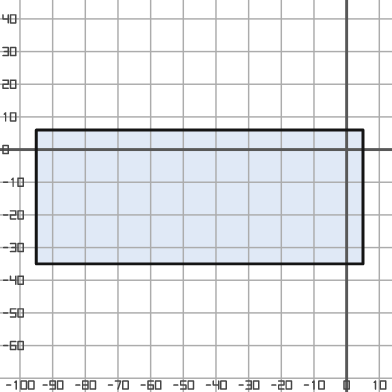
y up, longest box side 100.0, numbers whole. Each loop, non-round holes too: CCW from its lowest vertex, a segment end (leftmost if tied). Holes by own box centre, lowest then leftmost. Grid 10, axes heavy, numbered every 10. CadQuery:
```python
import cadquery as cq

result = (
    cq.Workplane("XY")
    .moveTo(-95.0, -35.0)
    .lineTo(5.0, -35.0)
    .lineTo(5.0, 6.0)
    .lineTo(-95.0, 6.0)
    .close()
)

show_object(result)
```